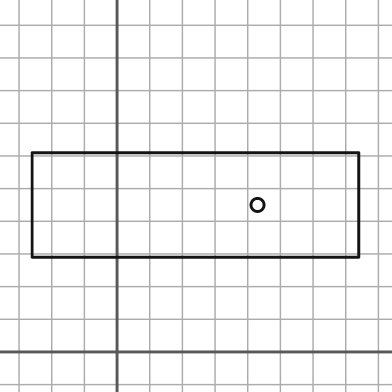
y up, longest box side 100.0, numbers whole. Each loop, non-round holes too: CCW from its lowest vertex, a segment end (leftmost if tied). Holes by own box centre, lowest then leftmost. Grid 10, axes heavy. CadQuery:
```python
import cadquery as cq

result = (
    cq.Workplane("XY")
    .moveTo(-26.0, 29.0)
    .lineTo(74.0, 29.0)
    .lineTo(74.0, 61.0)
    .lineTo(-26.0, 61.0)
    .close()
    .moveTo(43.0, 45.0)
    .circle(2.0)
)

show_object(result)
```